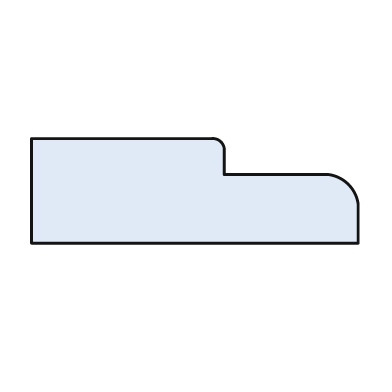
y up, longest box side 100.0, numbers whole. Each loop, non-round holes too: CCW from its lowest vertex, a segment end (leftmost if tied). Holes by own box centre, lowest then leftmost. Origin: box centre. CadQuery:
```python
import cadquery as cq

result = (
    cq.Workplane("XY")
    .moveTo(-50.0, -16.0)
    .lineTo(50.0, -16.0)
    .lineTo(50.0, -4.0)
    .threePointArc((47.0, 2.0), (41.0, 5.0))
    .lineTo(9.0, 5.0)
    .lineTo(9.0, 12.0)
    .threePointArc((8.0, 15.0), (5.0, 16.0))
    .lineTo(-50.0, 16.0)
    .close()
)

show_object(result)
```